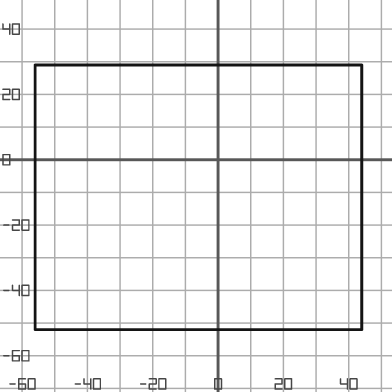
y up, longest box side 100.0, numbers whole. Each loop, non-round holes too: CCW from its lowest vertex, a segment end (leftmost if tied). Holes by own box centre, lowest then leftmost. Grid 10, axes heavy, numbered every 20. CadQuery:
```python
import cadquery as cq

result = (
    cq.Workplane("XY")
    .moveTo(-56.0, -52.0)
    .lineTo(44.0, -52.0)
    .lineTo(44.0, 29.0)
    .lineTo(-56.0, 29.0)
    .close()
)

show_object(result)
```